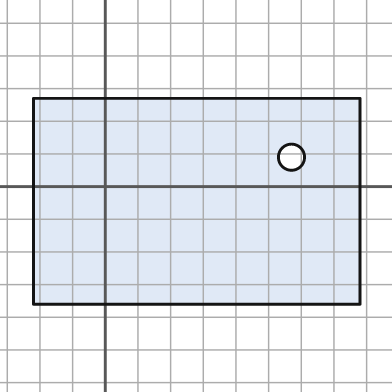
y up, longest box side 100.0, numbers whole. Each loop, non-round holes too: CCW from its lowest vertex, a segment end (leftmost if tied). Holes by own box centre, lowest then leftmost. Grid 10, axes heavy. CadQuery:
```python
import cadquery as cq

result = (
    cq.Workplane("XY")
    .moveTo(-22.0, -36.0)
    .lineTo(78.0, -36.0)
    .lineTo(78.0, 27.0)
    .lineTo(-22.0, 27.0)
    .close()
    .moveTo(57.0, 9.0)
    .circle(4.0)
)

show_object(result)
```